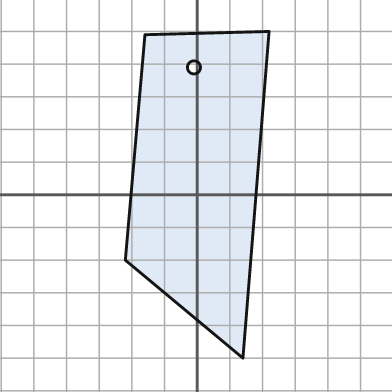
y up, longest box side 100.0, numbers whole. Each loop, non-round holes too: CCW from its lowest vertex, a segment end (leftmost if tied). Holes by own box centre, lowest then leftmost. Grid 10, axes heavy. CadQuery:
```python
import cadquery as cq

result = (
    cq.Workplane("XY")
    .moveTo(14.0, -50.0)
    .lineTo(22.0, 50.0)
    .lineTo(-16.0, 49.0)
    .lineTo(-22.0, -20.0)
    .close()
    .moveTo(-1.0, 39.0)
    .circle(2.0)
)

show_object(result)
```